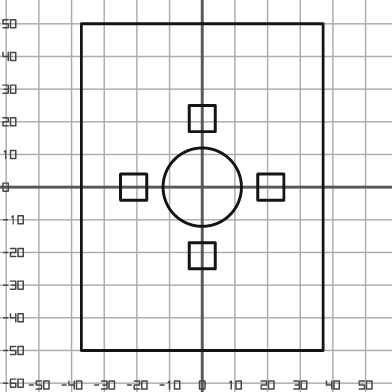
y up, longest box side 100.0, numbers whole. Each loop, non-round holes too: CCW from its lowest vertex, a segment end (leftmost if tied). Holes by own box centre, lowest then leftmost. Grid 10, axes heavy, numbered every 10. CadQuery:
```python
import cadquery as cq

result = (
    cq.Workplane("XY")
    .moveTo(-37.0, -50.0)
    .lineTo(37.0, -50.0)
    .lineTo(37.0, 50.0)
    .lineTo(-37.0, 50.0)
    .close()
    .moveTo(-4.0, -25.0)
    .lineTo(4.0, -25.0)
    .lineTo(4.0, -17.0)
    .lineTo(-4.0, -17.0)
    .close()
    .moveTo(-25.0, -4.0)
    .lineTo(-17.0, -4.0)
    .lineTo(-17.0, 4.0)
    .lineTo(-25.0, 4.0)
    .close()
    .moveTo(0.0, 0.0)
    .circle(12.0)
    .moveTo(17.0, -4.0)
    .lineTo(25.0, -4.0)
    .lineTo(25.0, 4.0)
    .lineTo(17.0, 4.0)
    .close()
    .moveTo(-4.0, 17.0)
    .lineTo(4.0, 17.0)
    .lineTo(4.0, 25.0)
    .lineTo(-4.0, 25.0)
    .close()
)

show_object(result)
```